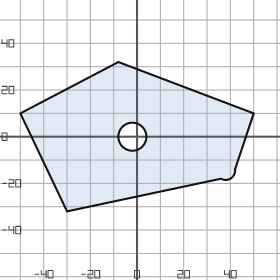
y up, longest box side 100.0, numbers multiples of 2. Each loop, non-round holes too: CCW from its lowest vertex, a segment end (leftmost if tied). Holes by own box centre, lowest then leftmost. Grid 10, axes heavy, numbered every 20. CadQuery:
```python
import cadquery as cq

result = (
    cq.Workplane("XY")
    .moveTo(-30.0, -32.0)
    .lineTo(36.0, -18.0)
    .threePointArc((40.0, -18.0), (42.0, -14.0))
    .lineTo(50.0, 10.0)
    .lineTo(-8.0, 32.0)
    .lineTo(-50.0, 10.0)
    .close()
    .moveTo(-2.0, 0.0)
    .circle(6.0)
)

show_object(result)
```